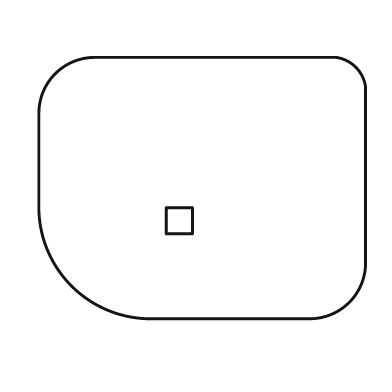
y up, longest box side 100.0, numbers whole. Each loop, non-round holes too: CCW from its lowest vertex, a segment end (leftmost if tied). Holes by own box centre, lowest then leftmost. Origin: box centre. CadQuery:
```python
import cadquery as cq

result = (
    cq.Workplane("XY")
    .moveTo(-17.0, -40.0)
    .lineTo(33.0, -40.0)
    .threePointArc((45.0, -35.0), (50.0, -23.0))
    .lineTo(50.0, 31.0)
    .threePointArc((47.0, 37.0), (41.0, 40.0))
    .lineTo(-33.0, 40.0)
    .threePointArc((-45.0, 35.0), (-50.0, 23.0))
    .lineTo(-50.0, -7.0)
    .threePointArc((-40.0, -30.0), (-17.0, -40.0))
    .close()
    .moveTo(-11.0, -14.0)
    .lineTo(-3.0, -14.0)
    .lineTo(-3.0, -6.0)
    .lineTo(-11.0, -6.0)
    .close()
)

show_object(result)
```